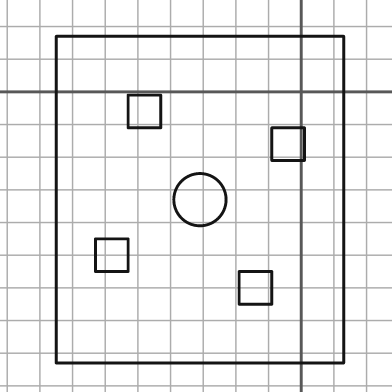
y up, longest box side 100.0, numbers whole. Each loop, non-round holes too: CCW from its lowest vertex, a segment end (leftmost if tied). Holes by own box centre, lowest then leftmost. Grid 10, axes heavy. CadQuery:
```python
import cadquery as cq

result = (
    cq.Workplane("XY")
    .moveTo(-75.0, -83.0)
    .lineTo(13.0, -83.0)
    .lineTo(13.0, 17.0)
    .lineTo(-75.0, 17.0)
    .close()
    .moveTo(-19.0, -65.0)
    .lineTo(-9.0, -65.0)
    .lineTo(-9.0, -55.0)
    .lineTo(-19.0, -55.0)
    .close()
    .moveTo(-63.0, -55.0)
    .lineTo(-53.0, -55.0)
    .lineTo(-53.0, -45.0)
    .lineTo(-63.0, -45.0)
    .close()
    .moveTo(-31.0, -33.0)
    .circle(8.0)
    .moveTo(-9.0, -21.0)
    .lineTo(1.0, -21.0)
    .lineTo(1.0, -11.0)
    .lineTo(-9.0, -11.0)
    .close()
    .moveTo(-53.0, -11.0)
    .lineTo(-43.0, -11.0)
    .lineTo(-43.0, -1.0)
    .lineTo(-53.0, -1.0)
    .close()
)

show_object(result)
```